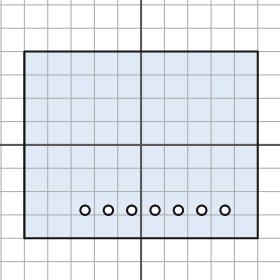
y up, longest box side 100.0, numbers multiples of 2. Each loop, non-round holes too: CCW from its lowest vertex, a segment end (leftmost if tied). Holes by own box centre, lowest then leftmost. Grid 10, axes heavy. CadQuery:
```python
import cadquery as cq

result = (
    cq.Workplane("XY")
    .moveTo(-50.0, -40.0)
    .lineTo(50.0, -40.0)
    .lineTo(50.0, 40.0)
    .lineTo(-50.0, 40.0)
    .close()
    .moveTo(-24.0, -28.0)
    .circle(2.0)
    .moveTo(-14.0, -28.0)
    .circle(2.0)
    .moveTo(-4.0, -28.0)
    .circle(2.0)
    .moveTo(6.0, -28.0)
    .circle(2.0)
    .moveTo(16.0, -28.0)
    .circle(2.0)
    .moveTo(26.0, -28.0)
    .circle(2.0)
    .moveTo(36.0, -28.0)
    .circle(2.0)
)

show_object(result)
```